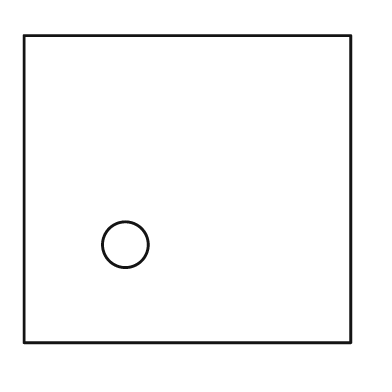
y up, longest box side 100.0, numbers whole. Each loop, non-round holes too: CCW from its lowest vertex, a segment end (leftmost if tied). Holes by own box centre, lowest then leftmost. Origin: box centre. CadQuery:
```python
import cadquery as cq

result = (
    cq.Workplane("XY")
    .moveTo(-50.0, -47.0)
    .lineTo(50.0, -47.0)
    .lineTo(50.0, 47.0)
    .lineTo(-50.0, 47.0)
    .close()
    .moveTo(-19.0, -17.0)
    .circle(7.0)
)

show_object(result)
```